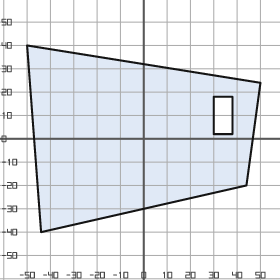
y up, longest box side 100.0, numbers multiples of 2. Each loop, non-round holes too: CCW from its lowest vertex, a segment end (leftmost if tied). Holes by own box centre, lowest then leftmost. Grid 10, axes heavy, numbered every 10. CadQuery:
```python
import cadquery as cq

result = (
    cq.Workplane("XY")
    .moveTo(-44.0, -40.0)
    .lineTo(44.0, -20.0)
    .lineTo(50.0, 24.0)
    .lineTo(-50.0, 40.0)
    .close()
    .moveTo(30.0, 2.0)
    .lineTo(38.0, 2.0)
    .lineTo(38.0, 18.0)
    .lineTo(30.0, 18.0)
    .close()
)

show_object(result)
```